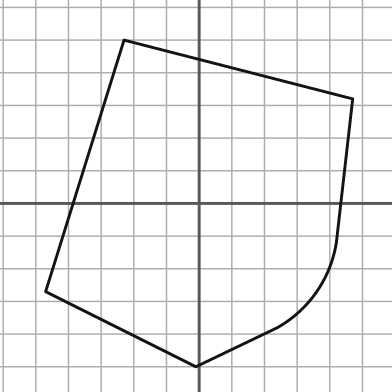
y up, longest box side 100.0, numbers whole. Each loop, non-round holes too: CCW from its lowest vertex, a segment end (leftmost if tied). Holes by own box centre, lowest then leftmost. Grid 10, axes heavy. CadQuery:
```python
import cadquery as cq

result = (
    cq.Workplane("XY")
    .moveTo(-1.0, -50.0)
    .lineTo(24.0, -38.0)
    .threePointArc((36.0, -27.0), (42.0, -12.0))
    .lineTo(47.0, 32.0)
    .lineTo(-23.0, 50.0)
    .lineTo(-47.0, -27.0)
    .close()
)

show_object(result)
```